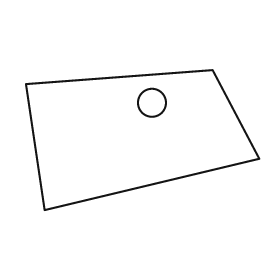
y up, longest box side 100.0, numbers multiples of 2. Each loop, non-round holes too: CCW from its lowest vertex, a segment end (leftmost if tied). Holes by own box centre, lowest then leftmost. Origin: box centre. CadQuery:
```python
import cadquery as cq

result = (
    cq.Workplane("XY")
    .moveTo(-42.0, -30.0)
    .lineTo(50.0, -8.0)
    .lineTo(30.0, 30.0)
    .lineTo(-50.0, 24.0)
    .close()
    .moveTo(4.0, 16.0)
    .circle(6.0)
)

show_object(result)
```